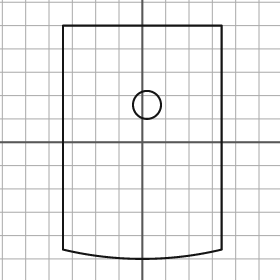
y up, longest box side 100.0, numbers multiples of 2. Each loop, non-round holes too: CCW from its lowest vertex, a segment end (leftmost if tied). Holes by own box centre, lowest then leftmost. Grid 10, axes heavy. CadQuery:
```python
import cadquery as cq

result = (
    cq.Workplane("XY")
    .moveTo(-34.0, -46.0)
    .threePointArc((0.0, -50.0), (34.0, -46.0))
    .lineTo(34.0, 50.0)
    .lineTo(-34.0, 50.0)
    .close()
    .moveTo(2.0, 16.0)
    .circle(6.0)
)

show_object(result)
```